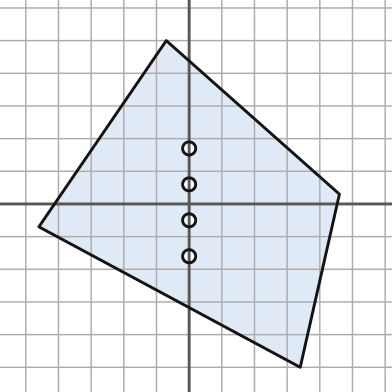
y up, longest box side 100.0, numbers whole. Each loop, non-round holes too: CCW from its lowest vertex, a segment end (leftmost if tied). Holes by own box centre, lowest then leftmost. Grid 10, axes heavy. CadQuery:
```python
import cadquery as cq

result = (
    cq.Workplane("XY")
    .moveTo(34.0, -50.0)
    .lineTo(46.0, 3.0)
    .lineTo(-7.0, 50.0)
    .lineTo(-46.0, -7.0)
    .close()
    .moveTo(0.0, -16.0)
    .circle(2.0)
    .moveTo(0.0, -5.0)
    .circle(2.0)
    .moveTo(0.0, 6.0)
    .circle(2.0)
    .moveTo(0.0, 17.0)
    .circle(2.0)
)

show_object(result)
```